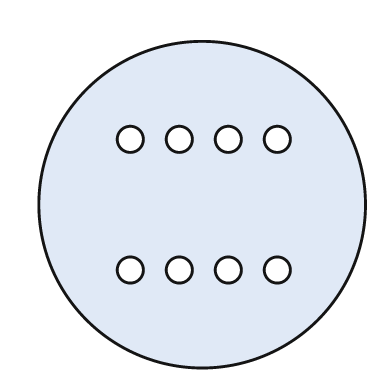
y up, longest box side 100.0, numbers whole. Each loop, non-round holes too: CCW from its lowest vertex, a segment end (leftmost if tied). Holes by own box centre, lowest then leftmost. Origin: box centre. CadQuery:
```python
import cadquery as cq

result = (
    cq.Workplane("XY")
    .moveTo(0.0, 0.0)
    .circle(50.0)
    .moveTo(-22.0, -20.0)
    .circle(4.0)
    .moveTo(-7.0, -20.0)
    .circle(4.0)
    .moveTo(8.0, -20.0)
    .circle(4.0)
    .moveTo(23.0, -20.0)
    .circle(4.0)
    .moveTo(-22.0, 20.0)
    .circle(4.0)
    .moveTo(-7.0, 20.0)
    .circle(4.0)
    .moveTo(8.0, 20.0)
    .circle(4.0)
    .moveTo(23.0, 20.0)
    .circle(4.0)
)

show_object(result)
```